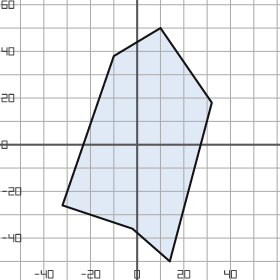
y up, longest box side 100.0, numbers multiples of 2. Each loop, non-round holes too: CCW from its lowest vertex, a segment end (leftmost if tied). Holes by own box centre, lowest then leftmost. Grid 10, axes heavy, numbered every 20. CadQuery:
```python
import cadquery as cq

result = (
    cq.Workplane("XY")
    .moveTo(14.0, -50.0)
    .lineTo(32.0, 18.0)
    .lineTo(10.0, 50.0)
    .lineTo(-10.0, 38.0)
    .lineTo(-32.0, -26.0)
    .lineTo(-2.0, -36.0)
    .close()
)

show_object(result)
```